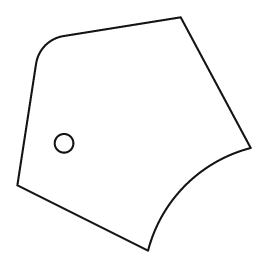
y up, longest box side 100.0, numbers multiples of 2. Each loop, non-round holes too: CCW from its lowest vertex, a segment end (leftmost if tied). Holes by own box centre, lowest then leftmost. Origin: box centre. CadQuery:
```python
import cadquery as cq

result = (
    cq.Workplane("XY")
    .moveTo(6.0, -50.0)
    .threePointArc((22.0, -22.0), (50.0, -6.0))
    .lineTo(20.0, 50.0)
    .lineTo(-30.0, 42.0)
    .threePointArc((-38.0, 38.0), (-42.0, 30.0))
    .lineTo(-50.0, -22.0)
    .close()
    .moveTo(-30.0, -4.0)
    .circle(4.0)
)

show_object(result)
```